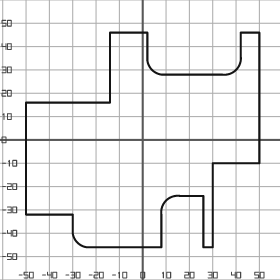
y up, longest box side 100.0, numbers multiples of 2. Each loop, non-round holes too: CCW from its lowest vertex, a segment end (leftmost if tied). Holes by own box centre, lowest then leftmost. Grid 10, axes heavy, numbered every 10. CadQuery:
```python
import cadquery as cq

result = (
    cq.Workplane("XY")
    .moveTo(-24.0, -46.0)
    .lineTo(8.0, -46.0)
    .lineTo(8.0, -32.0)
    .threePointArc((10.0, -26.0), (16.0, -24.0))
    .lineTo(26.0, -24.0)
    .lineTo(26.0, -46.0)
    .lineTo(30.0, -46.0)
    .lineTo(30.0, -10.0)
    .lineTo(50.0, -10.0)
    .lineTo(50.0, 46.0)
    .lineTo(42.0, 46.0)
    .lineTo(42.0, 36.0)
    .threePointArc((40.0, 30.0), (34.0, 28.0))
    .lineTo(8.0, 28.0)
    .threePointArc((4.0, 30.0), (2.0, 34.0))
    .lineTo(2.0, 46.0)
    .lineTo(-14.0, 46.0)
    .lineTo(-14.0, 16.0)
    .lineTo(-50.0, 16.0)
    .lineTo(-50.0, -32.0)
    .lineTo(-30.0, -32.0)
    .lineTo(-30.0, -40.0)
    .threePointArc((-28.0, -44.0), (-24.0, -46.0))
    .close()
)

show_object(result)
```